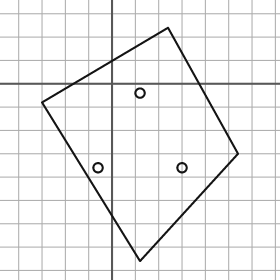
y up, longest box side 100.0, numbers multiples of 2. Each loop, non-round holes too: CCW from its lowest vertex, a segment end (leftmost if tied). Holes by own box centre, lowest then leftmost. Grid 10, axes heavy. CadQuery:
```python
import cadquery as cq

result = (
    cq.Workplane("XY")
    .moveTo(12.0, -76.0)
    .lineTo(54.0, -30.0)
    .lineTo(24.0, 24.0)
    .lineTo(-30.0, -8.0)
    .close()
    .moveTo(-6.0, -36.0)
    .circle(2.0)
    .moveTo(30.0, -36.0)
    .circle(2.0)
    .moveTo(12.0, -4.0)
    .circle(2.0)
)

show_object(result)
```